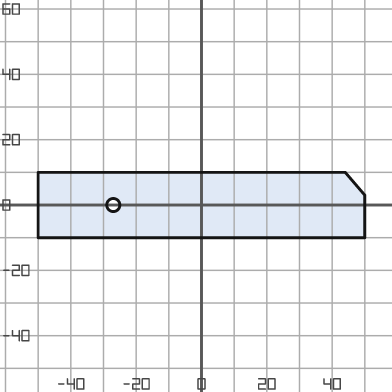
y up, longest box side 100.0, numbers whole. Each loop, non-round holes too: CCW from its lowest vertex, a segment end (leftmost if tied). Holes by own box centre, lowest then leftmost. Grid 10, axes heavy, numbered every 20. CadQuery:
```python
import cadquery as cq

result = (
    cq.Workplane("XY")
    .moveTo(-50.0, -10.0)
    .lineTo(50.0, -10.0)
    .lineTo(50.0, 3.0)
    .lineTo(44.0, 10.0)
    .lineTo(-50.0, 10.0)
    .close()
    .moveTo(-27.0, 0.0)
    .circle(2.0)
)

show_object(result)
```